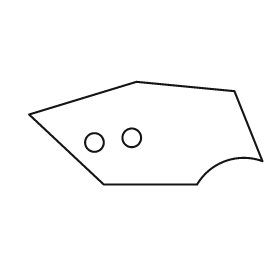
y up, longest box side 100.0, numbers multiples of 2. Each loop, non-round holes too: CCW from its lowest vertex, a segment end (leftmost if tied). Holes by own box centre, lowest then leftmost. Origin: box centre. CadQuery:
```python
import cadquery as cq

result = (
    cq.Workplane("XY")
    .moveTo(-18.0, -22.0)
    .lineTo(22.0, -22.0)
    .threePointArc((34.0, -12.0), (50.0, -12.0))
    .lineTo(38.0, 18.0)
    .lineTo(-4.0, 22.0)
    .lineTo(-50.0, 8.0)
    .close()
    .moveTo(-22.0, -4.0)
    .circle(4.0)
    .moveTo(-6.0, -2.0)
    .circle(4.0)
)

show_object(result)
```